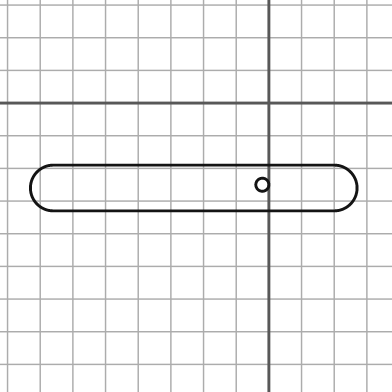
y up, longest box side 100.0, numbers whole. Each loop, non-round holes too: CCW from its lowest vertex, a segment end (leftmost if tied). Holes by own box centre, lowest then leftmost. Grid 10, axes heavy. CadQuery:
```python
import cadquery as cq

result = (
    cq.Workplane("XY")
    .moveTo(-66.0, -33.0)
    .lineTo(20.0, -33.0)
    .threePointArc((27.0, -26.0), (20.0, -19.0))
    .lineTo(-66.0, -19.0)
    .threePointArc((-73.0, -26.0), (-66.0, -33.0))
    .close()
    .moveTo(-2.0, -25.0)
    .circle(2.0)
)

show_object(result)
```